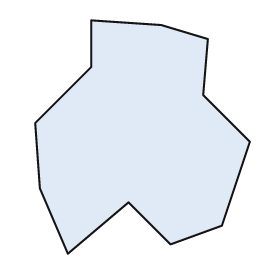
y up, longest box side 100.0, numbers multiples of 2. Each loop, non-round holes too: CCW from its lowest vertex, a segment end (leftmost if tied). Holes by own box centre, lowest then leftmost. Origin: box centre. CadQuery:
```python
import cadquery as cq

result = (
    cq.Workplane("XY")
    .moveTo(-32.0, -50.0)
    .lineTo(-6.0, -28.0)
    .lineTo(12.0, -46.0)
    .lineTo(34.0, -38.0)
    .lineTo(46.0, -2.0)
    .lineTo(26.0, 18.0)
    .lineTo(28.0, 42.0)
    .lineTo(8.0, 48.0)
    .lineTo(-22.0, 50.0)
    .lineTo(-22.0, 30.0)
    .lineTo(-46.0, 6.0)
    .lineTo(-44.0, -22.0)
    .close()
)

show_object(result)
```